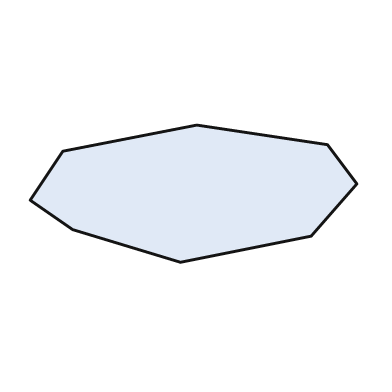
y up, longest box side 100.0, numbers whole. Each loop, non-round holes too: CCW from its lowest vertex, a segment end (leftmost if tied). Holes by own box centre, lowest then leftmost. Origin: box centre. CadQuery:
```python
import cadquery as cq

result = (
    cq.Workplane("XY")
    .moveTo(-4.0, -21.0)
    .lineTo(36.0, -13.0)
    .lineTo(50.0, 3.0)
    .lineTo(41.0, 15.0)
    .lineTo(1.0, 21.0)
    .lineTo(-40.0, 13.0)
    .lineTo(-50.0, -2.0)
    .lineTo(-37.0, -11.0)
    .close()
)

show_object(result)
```